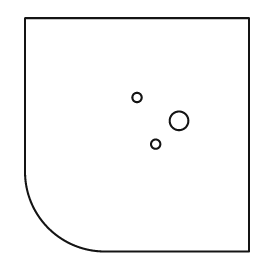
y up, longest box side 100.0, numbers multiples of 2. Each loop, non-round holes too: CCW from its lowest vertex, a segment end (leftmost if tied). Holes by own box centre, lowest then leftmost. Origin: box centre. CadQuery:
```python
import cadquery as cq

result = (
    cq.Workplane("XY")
    .moveTo(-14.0, -50.0)
    .lineTo(48.0, -50.0)
    .lineTo(48.0, 50.0)
    .lineTo(-48.0, 50.0)
    .lineTo(-48.0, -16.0)
    .threePointArc((-38.0, -40.0), (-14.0, -50.0))
    .close()
    .moveTo(8.0, -4.0)
    .circle(2.0)
    .moveTo(18.0, 6.0)
    .circle(4.0)
    .moveTo(0.0, 16.0)
    .circle(2.0)
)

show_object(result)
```